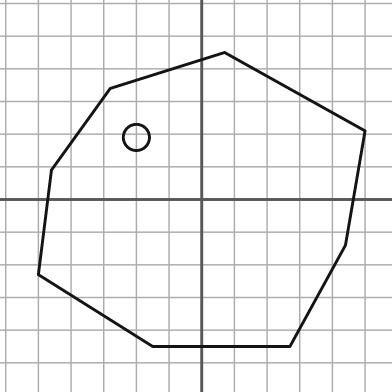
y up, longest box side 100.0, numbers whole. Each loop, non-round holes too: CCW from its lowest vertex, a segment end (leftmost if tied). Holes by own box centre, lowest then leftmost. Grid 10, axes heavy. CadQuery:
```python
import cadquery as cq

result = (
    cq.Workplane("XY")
    .moveTo(-15.0, -45.0)
    .lineTo(27.0, -45.0)
    .lineTo(44.0, -14.0)
    .lineTo(50.0, 21.0)
    .lineTo(7.0, 45.0)
    .lineTo(-28.0, 34.0)
    .lineTo(-46.0, 9.0)
    .lineTo(-50.0, -23.0)
    .close()
    .moveTo(-20.0, 19.0)
    .circle(4.0)
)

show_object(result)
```